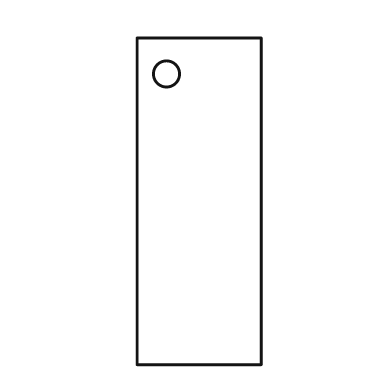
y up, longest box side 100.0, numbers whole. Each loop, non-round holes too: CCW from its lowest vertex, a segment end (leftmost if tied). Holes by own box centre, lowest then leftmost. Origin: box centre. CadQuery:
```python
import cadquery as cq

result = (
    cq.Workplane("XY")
    .moveTo(-19.0, -50.0)
    .lineTo(19.0, -50.0)
    .lineTo(19.0, 50.0)
    .lineTo(-19.0, 50.0)
    .close()
    .moveTo(-10.0, 39.0)
    .circle(4.0)
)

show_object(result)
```